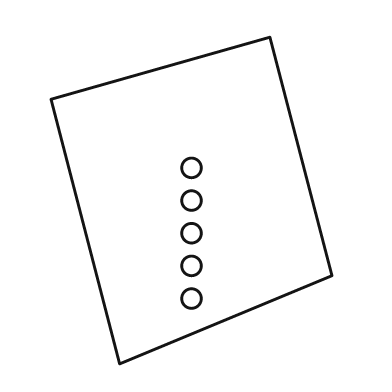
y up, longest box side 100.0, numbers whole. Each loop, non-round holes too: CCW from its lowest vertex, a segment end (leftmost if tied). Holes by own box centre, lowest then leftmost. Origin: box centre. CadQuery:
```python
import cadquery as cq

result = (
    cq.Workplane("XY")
    .moveTo(-22.0, -50.0)
    .lineTo(43.0, -23.0)
    .lineTo(24.0, 50.0)
    .lineTo(-43.0, 31.0)
    .close()
    .moveTo(0.0, -30.0)
    .circle(3.0)
    .moveTo(0.0, -20.0)
    .circle(3.0)
    .moveTo(0.0, -10.0)
    .circle(3.0)
    .moveTo(0.0, 0.0)
    .circle(3.0)
    .moveTo(0.0, 10.0)
    .circle(3.0)
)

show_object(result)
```